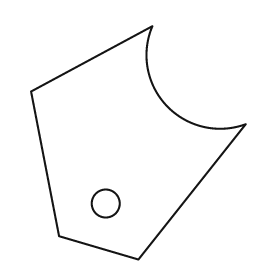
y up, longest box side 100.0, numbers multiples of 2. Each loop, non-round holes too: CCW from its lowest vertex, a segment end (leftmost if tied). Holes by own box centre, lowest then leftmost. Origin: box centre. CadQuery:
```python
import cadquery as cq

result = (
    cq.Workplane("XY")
    .moveTo(0.0, -50.0)
    .lineTo(46.0, 8.0)
    .threePointArc((12.0, 16.0), (6.0, 50.0))
    .lineTo(-46.0, 22.0)
    .lineTo(-34.0, -40.0)
    .close()
    .moveTo(-14.0, -26.0)
    .circle(6.0)
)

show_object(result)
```